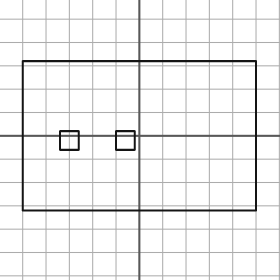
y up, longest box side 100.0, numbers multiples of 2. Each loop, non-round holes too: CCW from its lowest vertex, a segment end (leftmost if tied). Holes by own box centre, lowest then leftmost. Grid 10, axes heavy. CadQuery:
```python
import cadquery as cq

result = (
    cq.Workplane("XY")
    .moveTo(-50.0, -32.0)
    .lineTo(50.0, -32.0)
    .lineTo(50.0, 32.0)
    .lineTo(-50.0, 32.0)
    .close()
    .moveTo(-34.0, -6.0)
    .lineTo(-26.0, -6.0)
    .lineTo(-26.0, 2.0)
    .lineTo(-34.0, 2.0)
    .close()
    .moveTo(-10.0, -6.0)
    .lineTo(-2.0, -6.0)
    .lineTo(-2.0, 2.0)
    .lineTo(-10.0, 2.0)
    .close()
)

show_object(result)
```